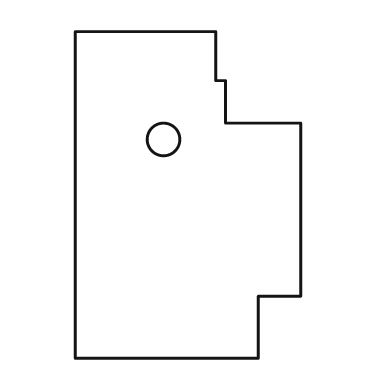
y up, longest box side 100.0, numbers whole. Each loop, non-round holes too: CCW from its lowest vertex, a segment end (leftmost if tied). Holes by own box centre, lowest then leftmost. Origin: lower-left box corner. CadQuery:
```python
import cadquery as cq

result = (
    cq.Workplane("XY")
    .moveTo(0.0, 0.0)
    .lineTo(56.0, 0.0)
    .lineTo(56.0, 19.0)
    .lineTo(69.0, 19.0)
    .lineTo(69.0, 72.0)
    .lineTo(46.0, 72.0)
    .lineTo(46.0, 85.0)
    .lineTo(43.0, 85.0)
    .lineTo(43.0, 100.0)
    .lineTo(0.0, 100.0)
    .close()
    .moveTo(27.0, 67.0)
    .circle(5.0)
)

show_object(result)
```